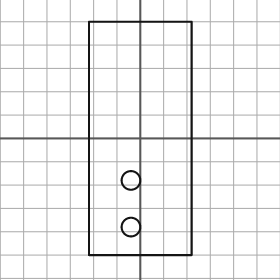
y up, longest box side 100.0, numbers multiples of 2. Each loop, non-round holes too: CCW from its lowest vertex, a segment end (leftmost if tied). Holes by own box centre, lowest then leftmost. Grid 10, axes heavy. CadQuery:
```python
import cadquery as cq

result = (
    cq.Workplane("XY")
    .moveTo(-22.0, -50.0)
    .lineTo(22.0, -50.0)
    .lineTo(22.0, 50.0)
    .lineTo(-22.0, 50.0)
    .close()
    .moveTo(-4.0, -38.0)
    .circle(4.0)
    .moveTo(-4.0, -18.0)
    .circle(4.0)
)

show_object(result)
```